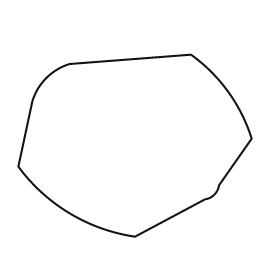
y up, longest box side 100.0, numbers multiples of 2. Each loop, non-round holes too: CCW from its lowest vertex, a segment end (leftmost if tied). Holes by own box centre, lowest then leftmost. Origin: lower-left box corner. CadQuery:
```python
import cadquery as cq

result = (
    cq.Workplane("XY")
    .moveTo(50.0, 0.0)
    .lineTo(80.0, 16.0)
    .threePointArc((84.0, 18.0), (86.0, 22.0))
    .lineTo(100.0, 42.0)
    .threePointArc((90.0, 62.0), (74.0, 78.0))
    .lineTo(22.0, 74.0)
    .threePointArc((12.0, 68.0), (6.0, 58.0))
    .lineTo(0.0, 30.0)
    .threePointArc((22.0, 10.0), (50.0, 0.0))
    .close()
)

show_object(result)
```